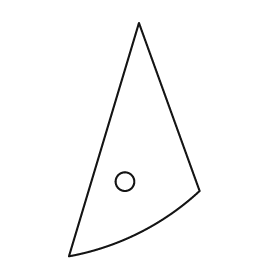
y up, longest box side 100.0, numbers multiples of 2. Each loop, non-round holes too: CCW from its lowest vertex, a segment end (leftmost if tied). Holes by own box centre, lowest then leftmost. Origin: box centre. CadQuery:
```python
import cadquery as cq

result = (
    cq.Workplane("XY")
    .moveTo(-28.0, -50.0)
    .threePointArc((2.0, -40.0), (28.0, -22.0))
    .lineTo(2.0, 50.0)
    .close()
    .moveTo(-4.0, -18.0)
    .circle(4.0)
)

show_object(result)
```